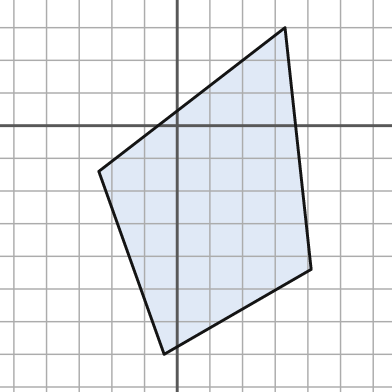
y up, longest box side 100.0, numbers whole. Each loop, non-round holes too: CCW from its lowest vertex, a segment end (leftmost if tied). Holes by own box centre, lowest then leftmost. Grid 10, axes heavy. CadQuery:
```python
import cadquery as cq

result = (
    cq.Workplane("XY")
    .moveTo(-4.0, -70.0)
    .lineTo(41.0, -44.0)
    .lineTo(33.0, 30.0)
    .lineTo(-24.0, -14.0)
    .close()
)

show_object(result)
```